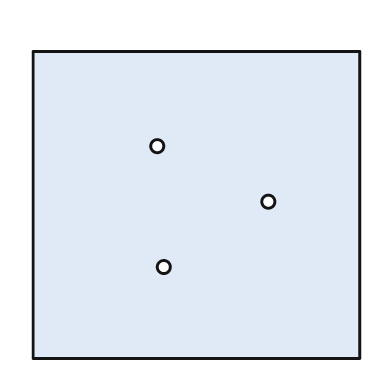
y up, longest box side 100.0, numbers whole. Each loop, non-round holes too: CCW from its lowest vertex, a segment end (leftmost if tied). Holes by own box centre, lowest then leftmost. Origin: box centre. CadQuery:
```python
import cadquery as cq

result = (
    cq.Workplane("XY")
    .moveTo(-50.0, -47.0)
    .lineTo(50.0, -47.0)
    .lineTo(50.0, 47.0)
    .lineTo(-50.0, 47.0)
    .close()
    .moveTo(-10.0, -19.0)
    .circle(2.0)
    .moveTo(22.0, 1.0)
    .circle(2.0)
    .moveTo(-12.0, 18.0)
    .circle(2.0)
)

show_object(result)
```